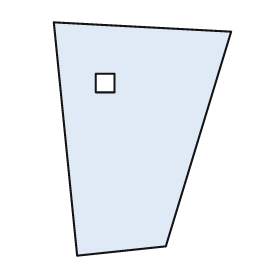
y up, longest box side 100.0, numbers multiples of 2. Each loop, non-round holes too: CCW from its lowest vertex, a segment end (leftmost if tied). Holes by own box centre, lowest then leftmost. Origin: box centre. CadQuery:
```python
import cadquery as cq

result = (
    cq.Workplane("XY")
    .moveTo(-28.0, -50.0)
    .lineTo(10.0, -46.0)
    .lineTo(38.0, 46.0)
    .lineTo(-38.0, 50.0)
    .close()
    .moveTo(-20.0, 20.0)
    .lineTo(-12.0, 20.0)
    .lineTo(-12.0, 28.0)
    .lineTo(-20.0, 28.0)
    .close()
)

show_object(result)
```